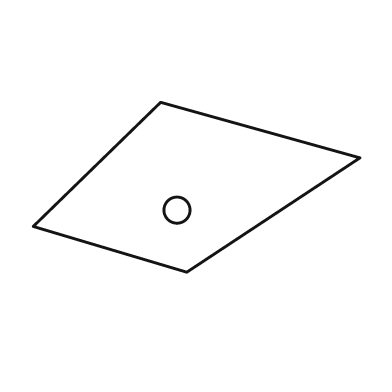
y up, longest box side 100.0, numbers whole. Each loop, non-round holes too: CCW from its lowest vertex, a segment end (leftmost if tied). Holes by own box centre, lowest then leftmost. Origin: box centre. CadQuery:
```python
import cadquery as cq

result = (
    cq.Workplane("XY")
    .moveTo(-3.0, -26.0)
    .lineTo(50.0, 9.0)
    .lineTo(-11.0, 26.0)
    .lineTo(-50.0, -12.0)
    .close()
    .moveTo(-6.0, -7.0)
    .circle(4.0)
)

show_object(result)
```